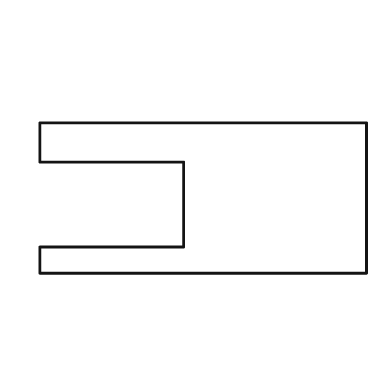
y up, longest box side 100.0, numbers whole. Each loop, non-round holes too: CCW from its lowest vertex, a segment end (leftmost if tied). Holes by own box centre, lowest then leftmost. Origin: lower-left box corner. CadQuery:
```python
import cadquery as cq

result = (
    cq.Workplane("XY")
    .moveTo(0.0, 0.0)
    .lineTo(100.0, 0.0)
    .lineTo(100.0, 46.0)
    .lineTo(0.0, 46.0)
    .lineTo(0.0, 34.0)
    .lineTo(44.0, 34.0)
    .lineTo(44.0, 8.0)
    .lineTo(0.0, 8.0)
    .close()
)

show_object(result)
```